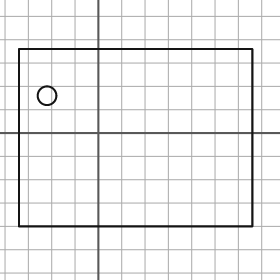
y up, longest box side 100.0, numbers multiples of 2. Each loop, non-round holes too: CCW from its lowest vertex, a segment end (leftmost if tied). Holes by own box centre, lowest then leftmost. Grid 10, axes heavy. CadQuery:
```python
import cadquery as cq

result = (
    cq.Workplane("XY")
    .moveTo(-34.0, -40.0)
    .lineTo(66.0, -40.0)
    .lineTo(66.0, 36.0)
    .lineTo(-34.0, 36.0)
    .close()
    .moveTo(-22.0, 16.0)
    .circle(4.0)
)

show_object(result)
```